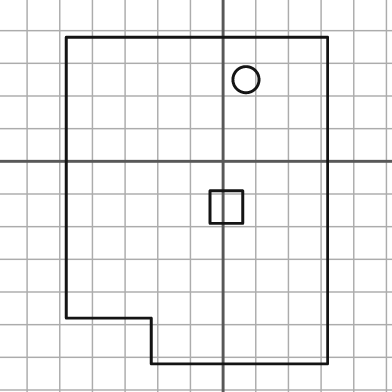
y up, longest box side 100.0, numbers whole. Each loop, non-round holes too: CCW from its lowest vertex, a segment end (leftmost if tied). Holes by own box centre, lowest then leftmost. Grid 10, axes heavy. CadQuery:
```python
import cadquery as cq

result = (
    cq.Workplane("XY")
    .moveTo(-22.0, -62.0)
    .lineTo(32.0, -62.0)
    .lineTo(32.0, 38.0)
    .lineTo(-48.0, 38.0)
    .lineTo(-48.0, -48.0)
    .lineTo(-22.0, -48.0)
    .close()
    .moveTo(-4.0, -19.0)
    .lineTo(6.0, -19.0)
    .lineTo(6.0, -9.0)
    .lineTo(-4.0, -9.0)
    .close()
    .moveTo(7.0, 25.0)
    .circle(4.0)
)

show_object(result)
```